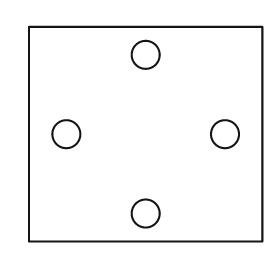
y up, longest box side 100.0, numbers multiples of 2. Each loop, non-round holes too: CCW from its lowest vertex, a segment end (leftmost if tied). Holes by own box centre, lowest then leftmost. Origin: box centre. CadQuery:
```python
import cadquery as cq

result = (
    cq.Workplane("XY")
    .moveTo(-50.0, -46.0)
    .lineTo(50.0, -46.0)
    .lineTo(50.0, 46.0)
    .lineTo(-50.0, 46.0)
    .close()
    .moveTo(0.0, -34.0)
    .circle(6.0)
    .moveTo(-34.0, 0.0)
    .circle(6.0)
    .moveTo(34.0, 0.0)
    .circle(6.0)
    .moveTo(0.0, 34.0)
    .circle(6.0)
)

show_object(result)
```